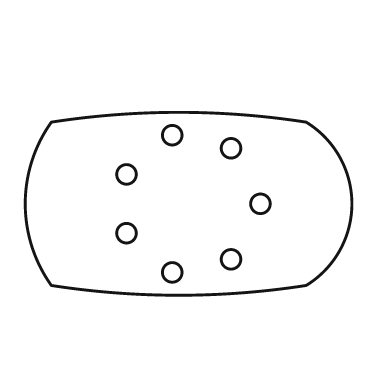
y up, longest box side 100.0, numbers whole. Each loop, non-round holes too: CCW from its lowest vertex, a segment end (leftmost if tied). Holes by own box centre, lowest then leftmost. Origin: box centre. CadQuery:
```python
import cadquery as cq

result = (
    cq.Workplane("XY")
    .moveTo(-42.0, -25.0)
    .threePointArc((-3.0, -28.0), (36.0, -25.0))
    .threePointArc((50.0, 0.0), (36.0, 25.0))
    .threePointArc((-3.0, 28.0), (-42.0, 25.0))
    .threePointArc((-50.0, 0.0), (-42.0, -25.0))
    .close()
    .moveTo(-5.0, -21.0)
    .circle(3.0)
    .moveTo(13.0, -17.0)
    .circle(3.0)
    .moveTo(-19.0, -9.0)
    .circle(3.0)
    .moveTo(22.0, 0.0)
    .circle(3.0)
    .moveTo(-19.0, 9.0)
    .circle(3.0)
    .moveTo(13.0, 17.0)
    .circle(3.0)
    .moveTo(-5.0, 21.0)
    .circle(3.0)
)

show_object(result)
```